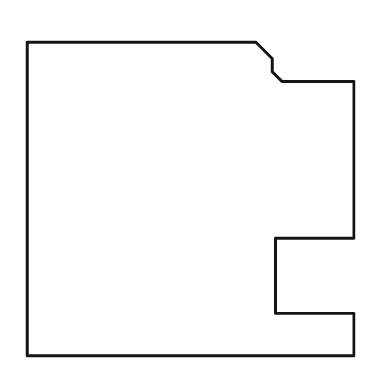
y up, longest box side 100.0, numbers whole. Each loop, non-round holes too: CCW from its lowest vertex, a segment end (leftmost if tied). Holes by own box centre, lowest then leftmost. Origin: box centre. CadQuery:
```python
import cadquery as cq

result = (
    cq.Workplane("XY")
    .moveTo(-50.0, -48.0)
    .lineTo(50.0, -48.0)
    .lineTo(50.0, -35.0)
    .lineTo(26.0, -35.0)
    .lineTo(26.0, -12.0)
    .lineTo(50.0, -12.0)
    .lineTo(50.0, 36.0)
    .lineTo(28.0, 36.0)
    .lineTo(25.0, 39.0)
    .lineTo(25.0, 43.0)
    .lineTo(20.0, 48.0)
    .lineTo(-50.0, 48.0)
    .close()
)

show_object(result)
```